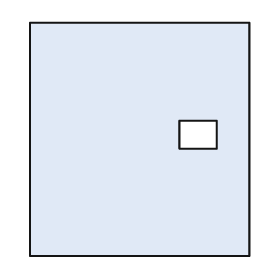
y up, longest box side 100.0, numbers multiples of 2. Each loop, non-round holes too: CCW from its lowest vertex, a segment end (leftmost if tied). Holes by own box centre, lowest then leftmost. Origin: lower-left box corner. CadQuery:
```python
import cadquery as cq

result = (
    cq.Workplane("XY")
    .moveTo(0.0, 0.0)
    .lineTo(94.0, 0.0)
    .lineTo(94.0, 100.0)
    .lineTo(0.0, 100.0)
    .close()
    .moveTo(64.0, 46.0)
    .lineTo(80.0, 46.0)
    .lineTo(80.0, 58.0)
    .lineTo(64.0, 58.0)
    .close()
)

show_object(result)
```